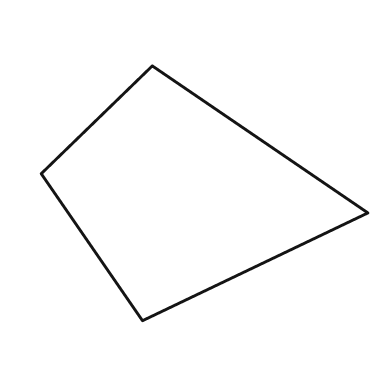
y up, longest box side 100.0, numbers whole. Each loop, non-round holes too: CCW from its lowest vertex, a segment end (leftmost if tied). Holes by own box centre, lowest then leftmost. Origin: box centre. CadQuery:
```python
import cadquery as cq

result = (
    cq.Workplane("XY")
    .moveTo(-19.0, -39.0)
    .lineTo(50.0, -6.0)
    .lineTo(-16.0, 39.0)
    .lineTo(-50.0, 6.0)
    .close()
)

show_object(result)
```